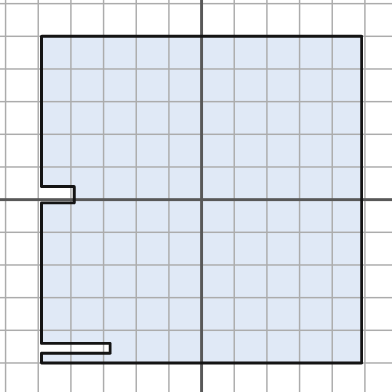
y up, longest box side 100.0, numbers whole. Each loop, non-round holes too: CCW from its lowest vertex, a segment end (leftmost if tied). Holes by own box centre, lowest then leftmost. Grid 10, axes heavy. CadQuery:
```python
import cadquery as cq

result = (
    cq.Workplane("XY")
    .moveTo(-49.0, -50.0)
    .lineTo(49.0, -50.0)
    .lineTo(49.0, 50.0)
    .lineTo(-49.0, 50.0)
    .lineTo(-49.0, 4.0)
    .lineTo(-39.0, 4.0)
    .lineTo(-39.0, -1.0)
    .lineTo(-49.0, -1.0)
    .lineTo(-49.0, -44.0)
    .lineTo(-28.0, -44.0)
    .lineTo(-28.0, -47.0)
    .lineTo(-49.0, -47.0)
    .close()
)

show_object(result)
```